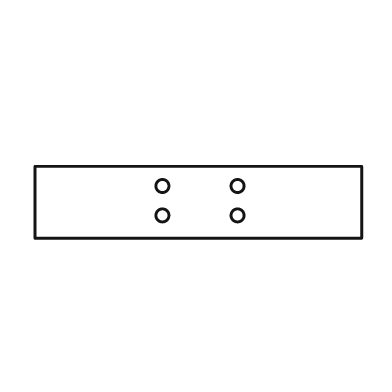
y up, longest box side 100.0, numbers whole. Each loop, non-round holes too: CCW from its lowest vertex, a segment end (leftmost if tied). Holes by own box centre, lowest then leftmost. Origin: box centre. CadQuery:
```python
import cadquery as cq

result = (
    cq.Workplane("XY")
    .moveTo(-50.0, -11.0)
    .lineTo(50.0, -11.0)
    .lineTo(50.0, 11.0)
    .lineTo(-50.0, 11.0)
    .close()
    .moveTo(-11.0, -4.0)
    .circle(2.0)
    .moveTo(12.0, -4.0)
    .circle(2.0)
    .moveTo(-11.0, 5.0)
    .circle(2.0)
    .moveTo(12.0, 5.0)
    .circle(2.0)
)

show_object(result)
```